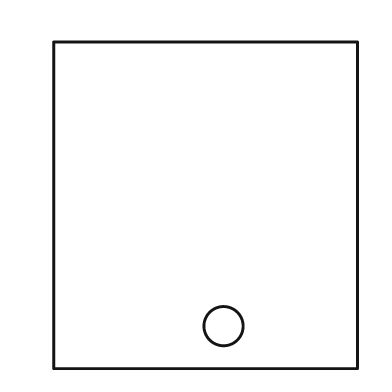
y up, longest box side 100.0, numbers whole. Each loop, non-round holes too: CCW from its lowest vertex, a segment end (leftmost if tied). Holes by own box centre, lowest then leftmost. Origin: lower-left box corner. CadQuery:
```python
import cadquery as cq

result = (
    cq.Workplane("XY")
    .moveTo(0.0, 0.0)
    .lineTo(93.0, 0.0)
    .lineTo(93.0, 100.0)
    .lineTo(0.0, 100.0)
    .close()
    .moveTo(52.0, 13.0)
    .circle(6.0)
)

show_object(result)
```